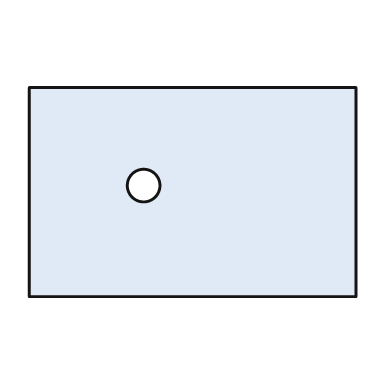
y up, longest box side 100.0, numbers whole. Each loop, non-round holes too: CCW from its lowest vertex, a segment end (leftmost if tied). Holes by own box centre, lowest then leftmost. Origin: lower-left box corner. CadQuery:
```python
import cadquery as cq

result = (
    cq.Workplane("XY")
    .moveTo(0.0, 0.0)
    .lineTo(100.0, 0.0)
    .lineTo(100.0, 64.0)
    .lineTo(0.0, 64.0)
    .close()
    .moveTo(35.0, 34.0)
    .circle(5.0)
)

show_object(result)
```